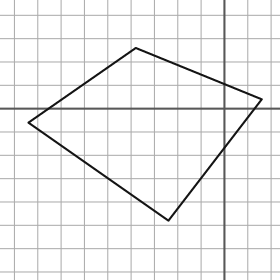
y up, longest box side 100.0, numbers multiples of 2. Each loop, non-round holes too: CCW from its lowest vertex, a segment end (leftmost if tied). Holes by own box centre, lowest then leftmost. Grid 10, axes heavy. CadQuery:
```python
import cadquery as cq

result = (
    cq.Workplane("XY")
    .moveTo(-24.0, -48.0)
    .lineTo(16.0, 4.0)
    .lineTo(-38.0, 26.0)
    .lineTo(-84.0, -6.0)
    .close()
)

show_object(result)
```